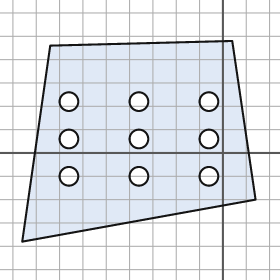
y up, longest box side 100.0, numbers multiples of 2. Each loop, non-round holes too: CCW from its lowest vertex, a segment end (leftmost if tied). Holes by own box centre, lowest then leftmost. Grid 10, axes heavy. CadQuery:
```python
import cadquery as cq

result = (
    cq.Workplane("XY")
    .moveTo(-86.0, -38.0)
    .lineTo(14.0, -20.0)
    .lineTo(4.0, 48.0)
    .lineTo(-74.0, 46.0)
    .close()
    .moveTo(-66.0, -10.0)
    .circle(4.0)
    .moveTo(-36.0, -10.0)
    .circle(4.0)
    .moveTo(-6.0, -10.0)
    .circle(4.0)
    .moveTo(-66.0, 6.0)
    .circle(4.0)
    .moveTo(-36.0, 6.0)
    .circle(4.0)
    .moveTo(-6.0, 6.0)
    .circle(4.0)
    .moveTo(-66.0, 22.0)
    .circle(4.0)
    .moveTo(-36.0, 22.0)
    .circle(4.0)
    .moveTo(-6.0, 22.0)
    .circle(4.0)
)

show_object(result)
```